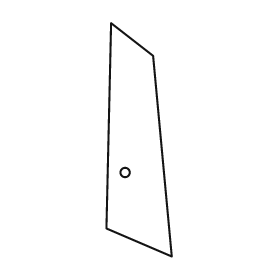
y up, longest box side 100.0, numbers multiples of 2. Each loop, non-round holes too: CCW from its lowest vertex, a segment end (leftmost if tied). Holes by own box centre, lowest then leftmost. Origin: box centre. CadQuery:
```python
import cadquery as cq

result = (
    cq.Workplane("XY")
    .moveTo(14.0, -50.0)
    .lineTo(6.0, 36.0)
    .lineTo(-12.0, 50.0)
    .lineTo(-14.0, -38.0)
    .close()
    .moveTo(-6.0, -14.0)
    .circle(2.0)
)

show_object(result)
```